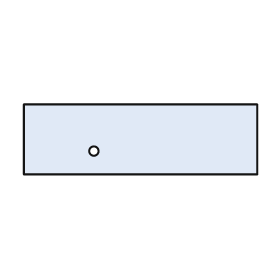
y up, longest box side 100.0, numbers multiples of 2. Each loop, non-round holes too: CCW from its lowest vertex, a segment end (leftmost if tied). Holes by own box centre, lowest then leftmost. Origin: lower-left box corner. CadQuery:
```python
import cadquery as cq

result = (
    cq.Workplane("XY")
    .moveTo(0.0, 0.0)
    .lineTo(100.0, 0.0)
    .lineTo(100.0, 30.0)
    .lineTo(0.0, 30.0)
    .close()
    .moveTo(30.0, 10.0)
    .circle(2.0)
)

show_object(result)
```